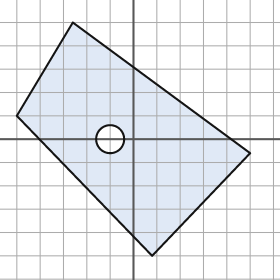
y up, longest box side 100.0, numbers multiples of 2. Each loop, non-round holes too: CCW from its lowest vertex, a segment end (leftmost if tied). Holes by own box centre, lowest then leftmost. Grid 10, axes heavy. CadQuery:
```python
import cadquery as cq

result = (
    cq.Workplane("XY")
    .moveTo(8.0, -50.0)
    .lineTo(50.0, -6.0)
    .lineTo(-26.0, 50.0)
    .lineTo(-50.0, 10.0)
    .close()
    .moveTo(-10.0, 0.0)
    .circle(6.0)
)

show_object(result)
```